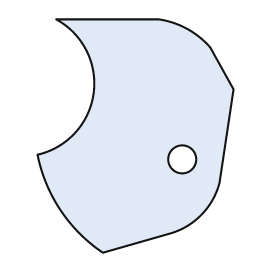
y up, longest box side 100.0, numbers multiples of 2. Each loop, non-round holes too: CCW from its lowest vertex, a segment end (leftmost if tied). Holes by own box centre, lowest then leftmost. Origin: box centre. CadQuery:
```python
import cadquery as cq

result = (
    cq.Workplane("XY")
    .moveTo(-14.0, -50.0)
    .lineTo(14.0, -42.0)
    .threePointArc((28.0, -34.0), (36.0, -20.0))
    .lineTo(42.0, 20.0)
    .lineTo(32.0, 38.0)
    .threePointArc((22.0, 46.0), (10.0, 50.0))
    .lineTo(-34.0, 50.0)
    .threePointArc((-18.0, 18.0), (-42.0, -8.0))
    .threePointArc((-32.0, -32.0), (-14.0, -50.0))
    .close()
    .moveTo(20.0, -10.0)
    .circle(6.0)
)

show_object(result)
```